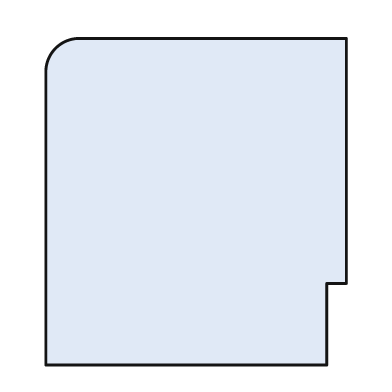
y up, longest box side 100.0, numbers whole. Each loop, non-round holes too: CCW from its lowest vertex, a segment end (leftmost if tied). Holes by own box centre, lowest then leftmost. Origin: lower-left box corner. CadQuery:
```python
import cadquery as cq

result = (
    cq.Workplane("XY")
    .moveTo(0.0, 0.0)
    .lineTo(86.0, 0.0)
    .lineTo(86.0, 25.0)
    .lineTo(92.0, 25.0)
    .lineTo(92.0, 100.0)
    .lineTo(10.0, 100.0)
    .threePointArc((3.0, 97.0), (0.0, 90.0))
    .close()
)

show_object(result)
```